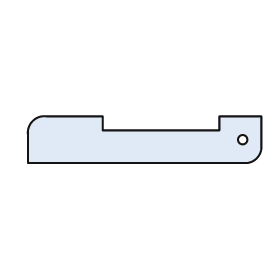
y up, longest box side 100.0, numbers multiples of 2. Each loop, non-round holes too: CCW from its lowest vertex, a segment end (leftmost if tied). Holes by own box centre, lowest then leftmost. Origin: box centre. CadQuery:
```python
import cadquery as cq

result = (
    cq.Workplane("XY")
    .moveTo(-50.0, -10.0)
    .lineTo(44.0, -10.0)
    .threePointArc((48.0, -8.0), (50.0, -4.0))
    .lineTo(50.0, 10.0)
    .lineTo(32.0, 10.0)
    .lineTo(32.0, 4.0)
    .lineTo(-18.0, 4.0)
    .lineTo(-18.0, 10.0)
    .lineTo(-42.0, 10.0)
    .threePointArc((-48.0, 8.0), (-50.0, 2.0))
    .close()
    .moveTo(42.0, 0.0)
    .circle(2.0)
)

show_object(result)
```